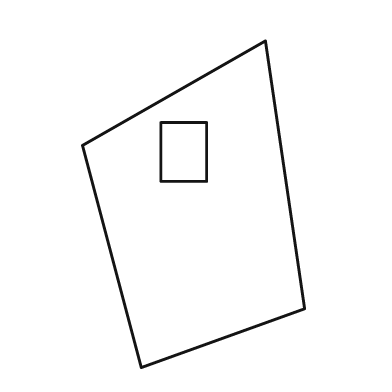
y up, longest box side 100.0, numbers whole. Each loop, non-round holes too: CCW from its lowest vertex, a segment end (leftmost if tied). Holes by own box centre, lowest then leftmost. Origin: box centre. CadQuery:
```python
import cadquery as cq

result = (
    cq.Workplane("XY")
    .moveTo(-16.0, -50.0)
    .lineTo(34.0, -32.0)
    .lineTo(22.0, 50.0)
    .lineTo(-34.0, 18.0)
    .close()
    .moveTo(-10.0, 7.0)
    .lineTo(4.0, 7.0)
    .lineTo(4.0, 25.0)
    .lineTo(-10.0, 25.0)
    .close()
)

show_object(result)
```